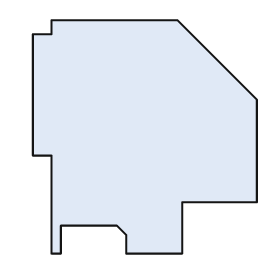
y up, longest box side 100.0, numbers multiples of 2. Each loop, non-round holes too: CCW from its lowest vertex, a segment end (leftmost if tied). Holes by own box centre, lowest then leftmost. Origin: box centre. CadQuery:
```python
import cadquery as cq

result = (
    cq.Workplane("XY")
    .moveTo(-40.0, -50.0)
    .lineTo(-36.0, -50.0)
    .lineTo(-36.0, -38.0)
    .lineTo(-12.0, -38.0)
    .lineTo(-8.0, -42.0)
    .lineTo(-8.0, -50.0)
    .lineTo(16.0, -50.0)
    .lineTo(16.0, -28.0)
    .lineTo(48.0, -28.0)
    .lineTo(48.0, 16.0)
    .lineTo(14.0, 50.0)
    .lineTo(-40.0, 50.0)
    .lineTo(-40.0, 44.0)
    .lineTo(-48.0, 44.0)
    .lineTo(-48.0, -8.0)
    .lineTo(-40.0, -8.0)
    .close()
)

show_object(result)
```